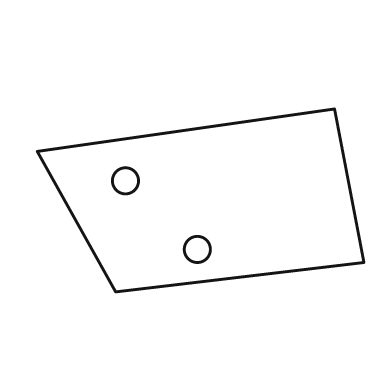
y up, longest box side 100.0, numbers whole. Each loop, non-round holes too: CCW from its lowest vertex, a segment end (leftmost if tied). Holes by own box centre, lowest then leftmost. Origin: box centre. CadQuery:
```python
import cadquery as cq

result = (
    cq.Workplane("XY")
    .moveTo(-26.0, -28.0)
    .lineTo(50.0, -19.0)
    .lineTo(41.0, 28.0)
    .lineTo(-50.0, 15.0)
    .close()
    .moveTo(-1.0, -15.0)
    .circle(4.0)
    .moveTo(-23.0, 6.0)
    .circle(4.0)
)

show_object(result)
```